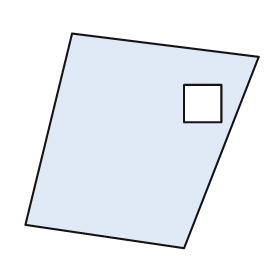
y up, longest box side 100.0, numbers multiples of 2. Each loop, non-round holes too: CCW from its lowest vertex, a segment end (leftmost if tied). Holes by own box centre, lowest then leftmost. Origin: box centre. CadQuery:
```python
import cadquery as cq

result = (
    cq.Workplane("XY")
    .moveTo(18.0, -46.0)
    .lineTo(50.0, 36.0)
    .lineTo(-30.0, 46.0)
    .lineTo(-50.0, -36.0)
    .close()
    .moveTo(18.0, 8.0)
    .lineTo(34.0, 8.0)
    .lineTo(34.0, 24.0)
    .lineTo(18.0, 24.0)
    .close()
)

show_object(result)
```